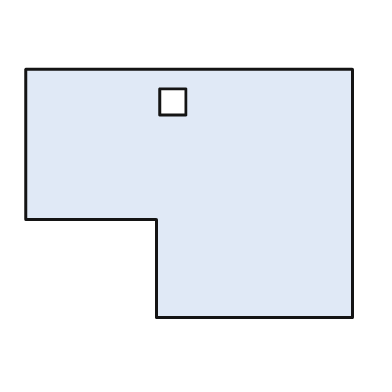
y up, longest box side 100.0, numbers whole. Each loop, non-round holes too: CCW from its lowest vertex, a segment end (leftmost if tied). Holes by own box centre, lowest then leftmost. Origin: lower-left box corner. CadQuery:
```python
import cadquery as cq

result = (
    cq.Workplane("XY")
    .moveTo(40.0, 0.0)
    .lineTo(100.0, 0.0)
    .lineTo(100.0, 76.0)
    .lineTo(0.0, 76.0)
    .lineTo(0.0, 30.0)
    .lineTo(40.0, 30.0)
    .close()
    .moveTo(41.0, 62.0)
    .lineTo(49.0, 62.0)
    .lineTo(49.0, 70.0)
    .lineTo(41.0, 70.0)
    .close()
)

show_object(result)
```